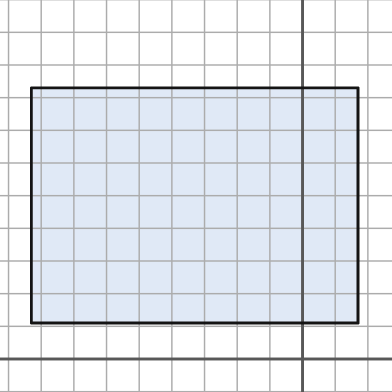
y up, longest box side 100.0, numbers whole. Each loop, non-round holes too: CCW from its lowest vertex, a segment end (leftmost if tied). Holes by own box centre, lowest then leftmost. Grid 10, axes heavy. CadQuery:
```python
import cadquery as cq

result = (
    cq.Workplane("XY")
    .moveTo(-83.0, 11.0)
    .lineTo(17.0, 11.0)
    .lineTo(17.0, 83.0)
    .lineTo(-83.0, 83.0)
    .close()
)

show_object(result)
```